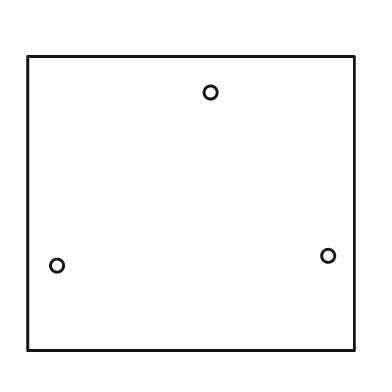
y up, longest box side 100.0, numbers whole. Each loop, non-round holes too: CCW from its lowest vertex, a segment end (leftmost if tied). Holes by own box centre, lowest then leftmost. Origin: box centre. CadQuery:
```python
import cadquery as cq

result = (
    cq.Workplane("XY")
    .moveTo(-50.0, -45.0)
    .lineTo(50.0, -45.0)
    .lineTo(50.0, 45.0)
    .lineTo(-50.0, 45.0)
    .close()
    .moveTo(-41.0, -19.0)
    .circle(2.0)
    .moveTo(42.0, -16.0)
    .circle(2.0)
    .moveTo(6.0, 34.0)
    .circle(2.0)
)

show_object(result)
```